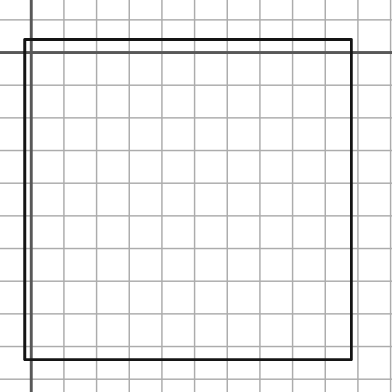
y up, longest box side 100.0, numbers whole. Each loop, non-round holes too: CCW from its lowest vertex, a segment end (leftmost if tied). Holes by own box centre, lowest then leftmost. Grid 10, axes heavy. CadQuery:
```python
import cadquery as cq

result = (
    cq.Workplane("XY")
    .moveTo(-2.0, -94.0)
    .lineTo(98.0, -94.0)
    .lineTo(98.0, 4.0)
    .lineTo(-2.0, 4.0)
    .close()
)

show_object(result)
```